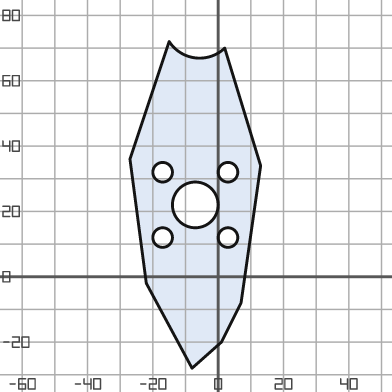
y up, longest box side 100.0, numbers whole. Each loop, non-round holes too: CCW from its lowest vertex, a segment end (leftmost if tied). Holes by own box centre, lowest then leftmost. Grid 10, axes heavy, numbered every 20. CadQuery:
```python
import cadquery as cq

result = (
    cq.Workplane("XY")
    .moveTo(-8.0, -28.0)
    .lineTo(1.0, -20.0)
    .lineTo(7.0, -8.0)
    .lineTo(13.0, 34.0)
    .lineTo(2.0, 70.0)
    .threePointArc((-7.0, 67.0), (-15.0, 72.0))
    .lineTo(-27.0, 36.0)
    .lineTo(-22.0, -2.0)
    .close()
    .moveTo(-17.0, 12.0)
    .circle(3.0)
    .moveTo(3.0, 12.0)
    .circle(3.0)
    .moveTo(-7.0, 22.0)
    .circle(7.0)
    .moveTo(-17.0, 32.0)
    .circle(3.0)
    .moveTo(3.0, 32.0)
    .circle(3.0)
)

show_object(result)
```